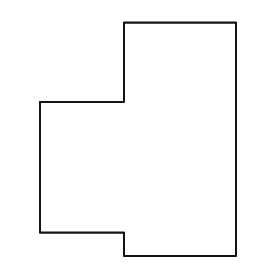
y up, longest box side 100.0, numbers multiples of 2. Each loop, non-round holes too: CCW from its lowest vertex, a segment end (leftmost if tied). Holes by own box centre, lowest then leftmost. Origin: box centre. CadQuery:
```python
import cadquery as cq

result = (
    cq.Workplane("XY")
    .moveTo(-6.0, -50.0)
    .lineTo(42.0, -50.0)
    .lineTo(42.0, 50.0)
    .lineTo(-6.0, 50.0)
    .lineTo(-6.0, 16.0)
    .lineTo(-42.0, 16.0)
    .lineTo(-42.0, -40.0)
    .lineTo(-6.0, -40.0)
    .close()
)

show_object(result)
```